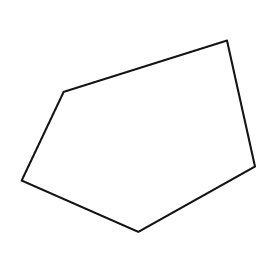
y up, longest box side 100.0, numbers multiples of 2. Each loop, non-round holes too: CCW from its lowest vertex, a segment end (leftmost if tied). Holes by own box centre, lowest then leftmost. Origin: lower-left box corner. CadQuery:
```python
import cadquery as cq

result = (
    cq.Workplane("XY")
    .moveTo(50.0, 0.0)
    .lineTo(100.0, 28.0)
    .lineTo(88.0, 82.0)
    .lineTo(18.0, 60.0)
    .lineTo(0.0, 22.0)
    .close()
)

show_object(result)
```